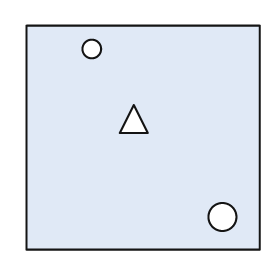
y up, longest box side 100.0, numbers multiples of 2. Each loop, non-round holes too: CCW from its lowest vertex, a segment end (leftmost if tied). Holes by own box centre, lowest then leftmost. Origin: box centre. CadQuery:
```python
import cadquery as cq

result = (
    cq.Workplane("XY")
    .moveTo(-50.0, -48.0)
    .lineTo(50.0, -48.0)
    .lineTo(50.0, 48.0)
    .lineTo(-50.0, 48.0)
    .close()
    .moveTo(34.0, -34.0)
    .circle(6.0)
    .moveTo(-10.0, 2.0)
    .lineTo(2.0, 2.0)
    .lineTo(-4.0, 14.0)
    .close()
    .moveTo(-22.0, 38.0)
    .circle(4.0)
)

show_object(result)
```